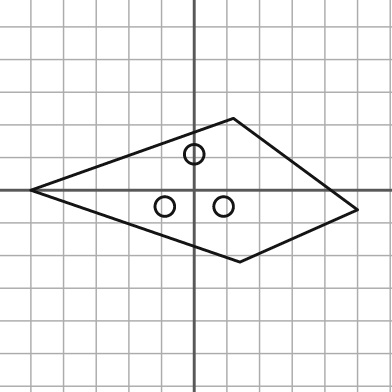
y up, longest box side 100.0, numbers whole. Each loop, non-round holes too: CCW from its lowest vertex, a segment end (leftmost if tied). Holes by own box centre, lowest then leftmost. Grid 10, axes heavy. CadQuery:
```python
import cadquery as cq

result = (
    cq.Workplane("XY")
    .moveTo(14.0, -22.0)
    .lineTo(50.0, -6.0)
    .lineTo(12.0, 22.0)
    .lineTo(-50.0, 0.0)
    .close()
    .moveTo(-9.0, -5.0)
    .circle(3.0)
    .moveTo(9.0, -5.0)
    .circle(3.0)
    .moveTo(0.0, 11.0)
    .circle(3.0)
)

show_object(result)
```